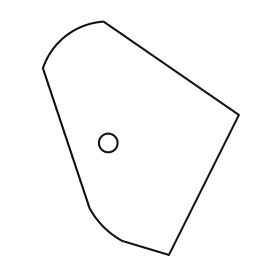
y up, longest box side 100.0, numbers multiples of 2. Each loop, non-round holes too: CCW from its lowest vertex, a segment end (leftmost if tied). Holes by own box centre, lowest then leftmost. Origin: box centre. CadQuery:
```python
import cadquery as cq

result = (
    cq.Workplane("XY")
    .moveTo(12.0, -50.0)
    .lineTo(42.0, 10.0)
    .lineTo(-16.0, 50.0)
    .threePointArc((-32.0, 44.0), (-42.0, 30.0))
    .lineTo(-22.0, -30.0)
    .threePointArc((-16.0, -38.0), (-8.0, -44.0))
    .close()
    .moveTo(-14.0, -2.0)
    .circle(4.0)
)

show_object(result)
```